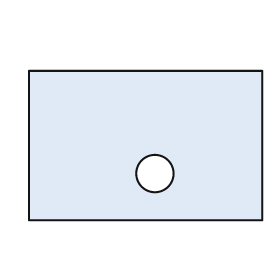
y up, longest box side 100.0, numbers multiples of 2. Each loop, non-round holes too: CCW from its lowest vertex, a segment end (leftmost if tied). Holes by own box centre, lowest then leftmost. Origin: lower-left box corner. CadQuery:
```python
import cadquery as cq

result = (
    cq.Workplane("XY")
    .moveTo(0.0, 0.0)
    .lineTo(100.0, 0.0)
    .lineTo(100.0, 64.0)
    .lineTo(0.0, 64.0)
    .close()
    .moveTo(54.0, 20.0)
    .circle(8.0)
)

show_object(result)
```